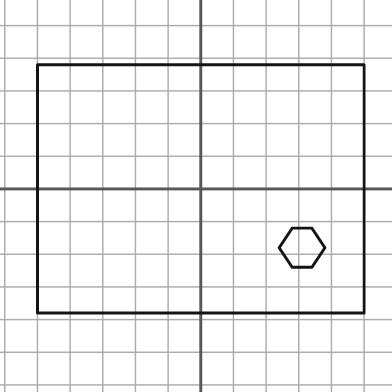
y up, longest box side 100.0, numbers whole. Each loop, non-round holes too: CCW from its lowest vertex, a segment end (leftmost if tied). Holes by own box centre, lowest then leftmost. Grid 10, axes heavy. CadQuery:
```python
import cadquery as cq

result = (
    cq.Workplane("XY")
    .moveTo(-50.0, -38.0)
    .lineTo(50.0, -38.0)
    .lineTo(50.0, 38.0)
    .lineTo(-50.0, 38.0)
    .close()
    .moveTo(28.0, -24.0)
    .lineTo(34.0, -24.0)
    .lineTo(38.0, -18.0)
    .lineTo(34.0, -12.0)
    .lineTo(28.0, -12.0)
    .lineTo(24.0, -18.0)
    .close()
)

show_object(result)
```